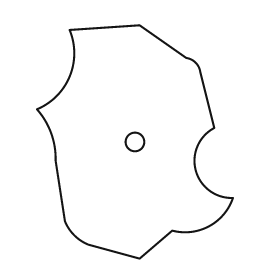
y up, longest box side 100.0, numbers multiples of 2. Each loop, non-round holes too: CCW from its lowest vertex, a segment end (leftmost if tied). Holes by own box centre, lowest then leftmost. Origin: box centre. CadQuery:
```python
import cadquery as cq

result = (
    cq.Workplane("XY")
    .moveTo(2.0, -50.0)
    .lineTo(16.0, -38.0)
    .threePointArc((32.0, -36.0), (42.0, -24.0))
    .threePointArc((26.0, -12.0), (34.0, 6.0))
    .lineTo(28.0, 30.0)
    .threePointArc((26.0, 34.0), (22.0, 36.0))
    .lineTo(2.0, 50.0)
    .lineTo(-28.0, 48.0)
    .threePointArc((-28.0, 28.0), (-42.0, 14.0))
    .threePointArc((-36.0, 4.0), (-34.0, -8.0))
    .lineTo(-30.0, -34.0)
    .threePointArc((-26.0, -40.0), (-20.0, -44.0))
    .close()
    .moveTo(0.0, 0.0)
    .circle(4.0)
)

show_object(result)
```